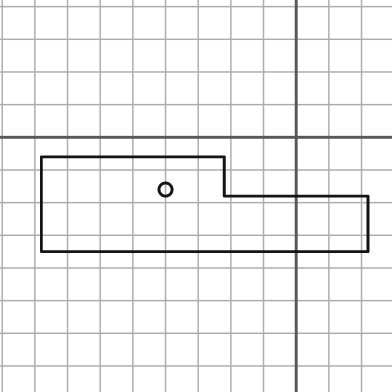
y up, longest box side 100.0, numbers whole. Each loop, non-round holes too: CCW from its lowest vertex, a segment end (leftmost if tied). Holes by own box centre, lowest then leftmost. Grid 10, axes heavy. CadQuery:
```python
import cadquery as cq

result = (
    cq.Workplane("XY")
    .moveTo(-78.0, -35.0)
    .lineTo(22.0, -35.0)
    .lineTo(22.0, -18.0)
    .lineTo(-22.0, -18.0)
    .lineTo(-22.0, -6.0)
    .lineTo(-78.0, -6.0)
    .close()
    .moveTo(-40.0, -16.0)
    .circle(2.0)
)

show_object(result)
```